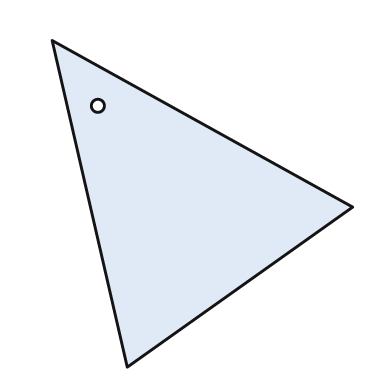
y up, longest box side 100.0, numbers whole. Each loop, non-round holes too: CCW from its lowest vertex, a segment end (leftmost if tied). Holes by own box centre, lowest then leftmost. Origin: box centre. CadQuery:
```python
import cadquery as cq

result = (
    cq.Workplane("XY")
    .moveTo(-23.0, -50.0)
    .lineTo(46.0, -1.0)
    .lineTo(-46.0, 50.0)
    .close()
    .moveTo(-32.0, 30.0)
    .circle(2.0)
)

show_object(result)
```